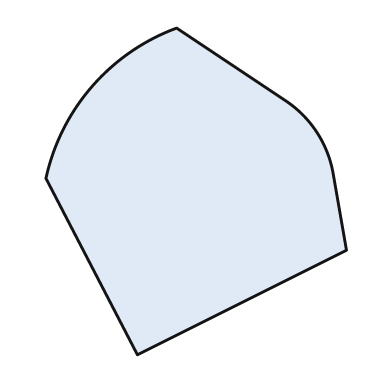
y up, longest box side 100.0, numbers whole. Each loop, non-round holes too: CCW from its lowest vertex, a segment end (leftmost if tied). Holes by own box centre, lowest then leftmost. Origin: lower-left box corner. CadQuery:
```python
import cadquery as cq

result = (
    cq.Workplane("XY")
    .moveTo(28.0, 0.0)
    .lineTo(92.0, 32.0)
    .lineTo(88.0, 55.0)
    .threePointArc((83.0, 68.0), (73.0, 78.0))
    .lineTo(40.0, 100.0)
    .threePointArc((14.0, 82.0), (0.0, 54.0))
    .close()
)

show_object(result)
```